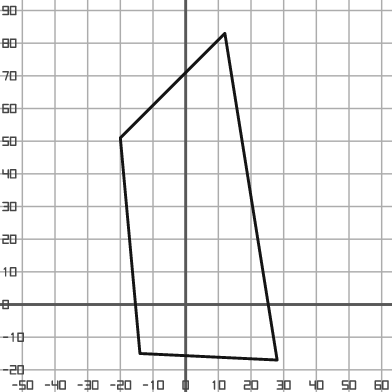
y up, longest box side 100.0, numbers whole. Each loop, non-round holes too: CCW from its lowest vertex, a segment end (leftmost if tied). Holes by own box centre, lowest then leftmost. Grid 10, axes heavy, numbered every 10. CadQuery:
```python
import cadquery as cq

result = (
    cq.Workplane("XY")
    .moveTo(28.0, -17.0)
    .lineTo(12.0, 83.0)
    .lineTo(-20.0, 51.0)
    .lineTo(-14.0, -15.0)
    .close()
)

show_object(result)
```